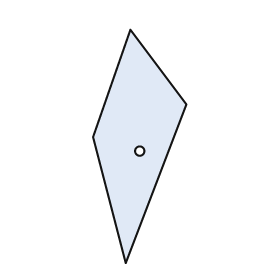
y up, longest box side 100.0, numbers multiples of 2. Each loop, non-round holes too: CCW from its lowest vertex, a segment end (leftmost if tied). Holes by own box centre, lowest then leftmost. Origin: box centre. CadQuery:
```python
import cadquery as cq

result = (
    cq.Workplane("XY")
    .moveTo(-6.0, -50.0)
    .lineTo(20.0, 18.0)
    .lineTo(-4.0, 50.0)
    .lineTo(-20.0, 4.0)
    .close()
    .moveTo(0.0, -2.0)
    .circle(2.0)
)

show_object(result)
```